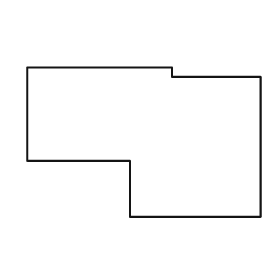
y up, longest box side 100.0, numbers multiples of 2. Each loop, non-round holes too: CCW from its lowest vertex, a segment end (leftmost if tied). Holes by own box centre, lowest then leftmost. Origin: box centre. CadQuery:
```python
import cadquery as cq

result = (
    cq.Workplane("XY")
    .moveTo(-6.0, -32.0)
    .lineTo(50.0, -32.0)
    .lineTo(50.0, 28.0)
    .lineTo(12.0, 28.0)
    .lineTo(12.0, 32.0)
    .lineTo(-50.0, 32.0)
    .lineTo(-50.0, -8.0)
    .lineTo(-6.0, -8.0)
    .close()
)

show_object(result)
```